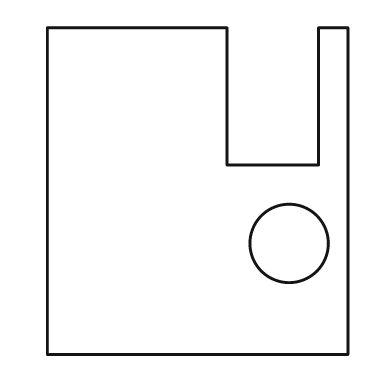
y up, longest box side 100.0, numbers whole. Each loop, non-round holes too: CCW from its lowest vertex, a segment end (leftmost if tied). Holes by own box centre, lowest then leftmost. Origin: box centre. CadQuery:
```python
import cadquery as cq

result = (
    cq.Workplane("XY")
    .moveTo(-46.0, -50.0)
    .lineTo(46.0, -50.0)
    .lineTo(46.0, 50.0)
    .lineTo(37.0, 50.0)
    .lineTo(37.0, 8.0)
    .lineTo(9.0, 8.0)
    .lineTo(9.0, 50.0)
    .lineTo(-46.0, 50.0)
    .close()
    .moveTo(28.0, -16.0)
    .circle(12.0)
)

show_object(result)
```